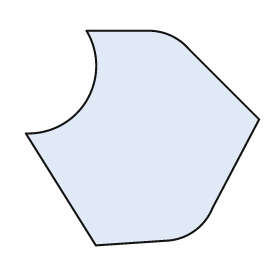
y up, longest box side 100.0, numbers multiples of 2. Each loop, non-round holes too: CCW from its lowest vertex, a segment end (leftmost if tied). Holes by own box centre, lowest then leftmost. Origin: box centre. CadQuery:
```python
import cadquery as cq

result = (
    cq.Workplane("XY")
    .moveTo(-20.0, -46.0)
    .lineTo(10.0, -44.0)
    .threePointArc((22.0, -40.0), (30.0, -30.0))
    .lineTo(50.0, 8.0)
    .lineTo(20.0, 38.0)
    .threePointArc((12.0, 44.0), (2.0, 46.0))
    .lineTo(-24.0, 46.0)
    .threePointArc((-24.0, 16.0), (-50.0, 2.0))
    .close()
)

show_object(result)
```